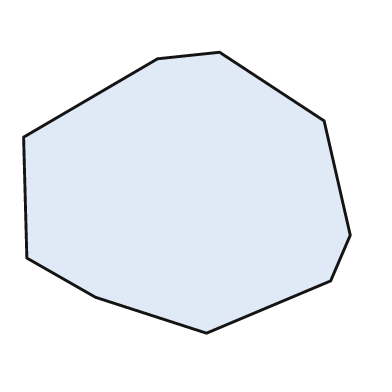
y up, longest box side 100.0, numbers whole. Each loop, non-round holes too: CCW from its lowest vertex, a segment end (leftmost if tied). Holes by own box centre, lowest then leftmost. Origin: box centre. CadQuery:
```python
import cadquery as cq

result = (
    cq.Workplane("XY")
    .moveTo(6.0, -43.0)
    .lineTo(44.0, -27.0)
    .lineTo(50.0, -13.0)
    .lineTo(42.0, 22.0)
    .lineTo(10.0, 43.0)
    .lineTo(-9.0, 41.0)
    .lineTo(-50.0, 17.0)
    .lineTo(-49.0, -20.0)
    .lineTo(-28.0, -32.0)
    .close()
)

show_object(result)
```